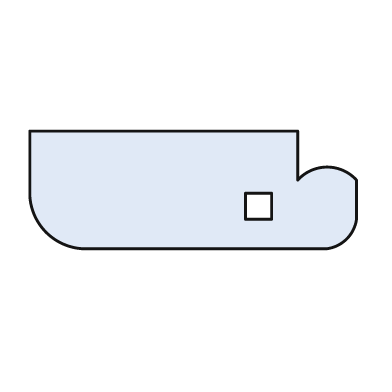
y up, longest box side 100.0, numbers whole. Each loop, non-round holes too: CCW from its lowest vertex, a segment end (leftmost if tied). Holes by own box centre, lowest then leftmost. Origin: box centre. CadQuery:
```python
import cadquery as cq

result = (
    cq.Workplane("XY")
    .moveTo(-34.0, -18.0)
    .lineTo(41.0, -18.0)
    .threePointArc((47.0, -15.0), (50.0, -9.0))
    .lineTo(50.0, 3.0)
    .threePointArc((41.0, 7.0), (32.0, 3.0))
    .lineTo(32.0, 18.0)
    .lineTo(-50.0, 18.0)
    .lineTo(-50.0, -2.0)
    .threePointArc((-45.0, -13.0), (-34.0, -18.0))
    .close()
    .moveTo(16.0, -9.0)
    .lineTo(24.0, -9.0)
    .lineTo(24.0, -1.0)
    .lineTo(16.0, -1.0)
    .close()
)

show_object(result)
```